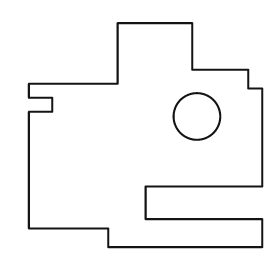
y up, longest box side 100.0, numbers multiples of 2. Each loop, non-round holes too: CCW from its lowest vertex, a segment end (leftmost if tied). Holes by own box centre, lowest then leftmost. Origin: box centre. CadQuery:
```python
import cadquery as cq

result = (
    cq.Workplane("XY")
    .moveTo(-16.0, -48.0)
    .lineTo(50.0, -48.0)
    .lineTo(50.0, -36.0)
    .lineTo(0.0, -36.0)
    .lineTo(0.0, -22.0)
    .lineTo(50.0, -22.0)
    .lineTo(50.0, 20.0)
    .lineTo(44.0, 20.0)
    .lineTo(44.0, 28.0)
    .lineTo(20.0, 28.0)
    .lineTo(20.0, 48.0)
    .lineTo(-12.0, 48.0)
    .lineTo(-12.0, 22.0)
    .lineTo(-50.0, 22.0)
    .lineTo(-50.0, 16.0)
    .lineTo(-40.0, 16.0)
    .lineTo(-40.0, 10.0)
    .lineTo(-50.0, 10.0)
    .lineTo(-50.0, -40.0)
    .lineTo(-16.0, -40.0)
    .close()
    .moveTo(22.0, 8.0)
    .circle(10.0)
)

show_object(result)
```